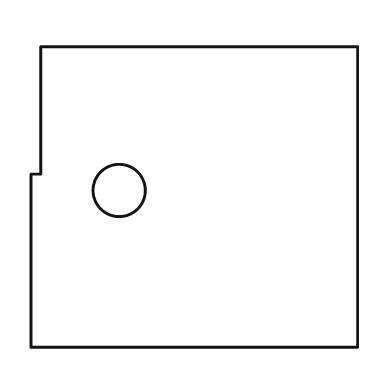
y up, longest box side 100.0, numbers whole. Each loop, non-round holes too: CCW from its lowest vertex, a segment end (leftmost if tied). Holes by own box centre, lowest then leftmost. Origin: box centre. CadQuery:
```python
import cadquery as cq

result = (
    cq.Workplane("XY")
    .moveTo(-50.0, -46.0)
    .lineTo(50.0, -46.0)
    .lineTo(50.0, 46.0)
    .lineTo(-47.0, 46.0)
    .lineTo(-47.0, 7.0)
    .lineTo(-50.0, 7.0)
    .close()
    .moveTo(-23.0, 2.0)
    .circle(8.0)
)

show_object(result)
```